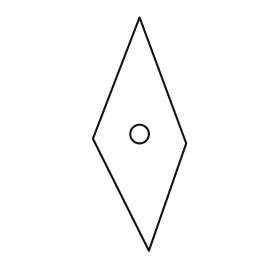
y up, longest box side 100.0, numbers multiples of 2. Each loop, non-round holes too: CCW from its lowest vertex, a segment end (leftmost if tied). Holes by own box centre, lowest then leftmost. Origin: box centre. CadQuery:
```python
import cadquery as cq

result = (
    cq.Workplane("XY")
    .moveTo(4.0, -50.0)
    .lineTo(20.0, -4.0)
    .lineTo(0.0, 50.0)
    .lineTo(-20.0, -2.0)
    .close()
    .moveTo(0.0, 0.0)
    .circle(4.0)
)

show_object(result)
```